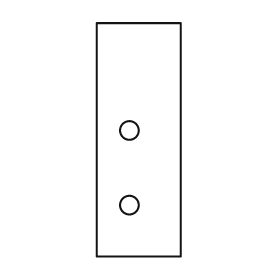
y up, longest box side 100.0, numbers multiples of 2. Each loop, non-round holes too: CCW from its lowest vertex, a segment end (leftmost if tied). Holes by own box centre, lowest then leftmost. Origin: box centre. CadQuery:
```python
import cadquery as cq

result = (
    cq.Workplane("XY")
    .moveTo(-18.0, -50.0)
    .lineTo(18.0, -50.0)
    .lineTo(18.0, 50.0)
    .lineTo(-18.0, 50.0)
    .close()
    .moveTo(-4.0, -28.0)
    .circle(4.0)
    .moveTo(-4.0, 4.0)
    .circle(4.0)
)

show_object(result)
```